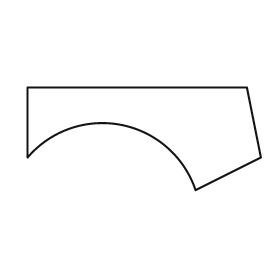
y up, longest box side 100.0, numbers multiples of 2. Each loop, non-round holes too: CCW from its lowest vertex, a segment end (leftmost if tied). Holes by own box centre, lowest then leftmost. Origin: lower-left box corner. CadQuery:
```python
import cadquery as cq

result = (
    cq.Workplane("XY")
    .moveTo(72.0, 0.0)
    .lineTo(100.0, 14.0)
    .lineTo(94.0, 44.0)
    .lineTo(0.0, 44.0)
    .lineTo(0.0, 14.0)
    .threePointArc((40.0, 28.0), (72.0, 0.0))
    .close()
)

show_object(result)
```